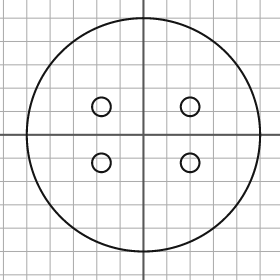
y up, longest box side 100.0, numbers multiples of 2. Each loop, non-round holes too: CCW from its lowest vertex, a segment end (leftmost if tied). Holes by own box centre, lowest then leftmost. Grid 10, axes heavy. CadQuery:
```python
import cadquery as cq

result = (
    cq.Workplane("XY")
    .moveTo(0.0, 0.0)
    .circle(50.0)
    .moveTo(-18.0, -12.0)
    .circle(4.0)
    .moveTo(20.0, -12.0)
    .circle(4.0)
    .moveTo(-18.0, 12.0)
    .circle(4.0)
    .moveTo(20.0, 12.0)
    .circle(4.0)
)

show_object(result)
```